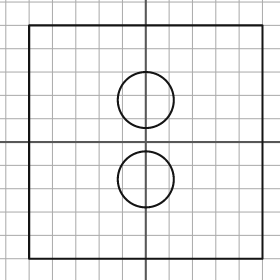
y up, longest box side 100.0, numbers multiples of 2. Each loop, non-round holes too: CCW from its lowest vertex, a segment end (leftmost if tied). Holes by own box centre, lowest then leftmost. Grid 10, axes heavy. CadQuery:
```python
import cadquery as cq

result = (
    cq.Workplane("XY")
    .moveTo(-50.0, -50.0)
    .lineTo(50.0, -50.0)
    .lineTo(50.0, 50.0)
    .lineTo(-50.0, 50.0)
    .close()
    .moveTo(0.0, -16.0)
    .circle(12.0)
    .moveTo(0.0, 18.0)
    .circle(12.0)
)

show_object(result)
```